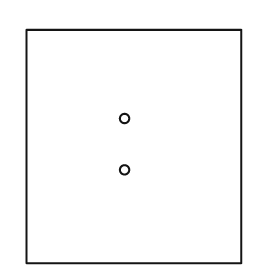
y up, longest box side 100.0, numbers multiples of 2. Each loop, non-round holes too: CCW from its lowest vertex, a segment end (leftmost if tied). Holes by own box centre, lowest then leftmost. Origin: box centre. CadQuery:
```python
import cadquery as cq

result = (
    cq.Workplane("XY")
    .moveTo(-46.0, -50.0)
    .lineTo(46.0, -50.0)
    .lineTo(46.0, 50.0)
    .lineTo(-46.0, 50.0)
    .close()
    .moveTo(-4.0, -10.0)
    .circle(2.0)
    .moveTo(-4.0, 12.0)
    .circle(2.0)
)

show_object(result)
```